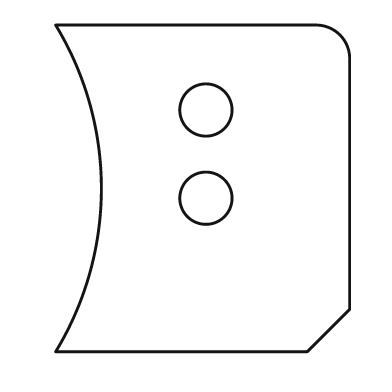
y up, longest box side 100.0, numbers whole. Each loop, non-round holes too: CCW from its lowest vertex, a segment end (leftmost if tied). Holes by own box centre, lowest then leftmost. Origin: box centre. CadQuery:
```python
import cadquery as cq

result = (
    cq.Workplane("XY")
    .moveTo(-45.0, -50.0)
    .lineTo(32.0, -50.0)
    .lineTo(45.0, -37.0)
    .lineTo(45.0, 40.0)
    .threePointArc((42.0, 47.0), (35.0, 50.0))
    .lineTo(-45.0, 50.0)
    .threePointArc((-31.0, 0.0), (-45.0, -50.0))
    .close()
    .moveTo(1.0, -3.0)
    .circle(8.0)
    .moveTo(1.0, 24.0)
    .circle(8.0)
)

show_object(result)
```